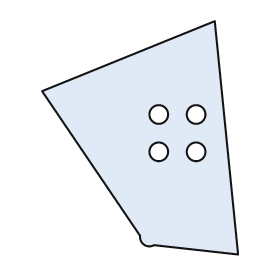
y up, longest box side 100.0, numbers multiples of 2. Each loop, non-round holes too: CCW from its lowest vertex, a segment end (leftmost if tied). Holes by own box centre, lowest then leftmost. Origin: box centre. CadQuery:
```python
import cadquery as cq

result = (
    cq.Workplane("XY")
    .moveTo(42.0, -50.0)
    .lineTo(32.0, 50.0)
    .lineTo(-42.0, 20.0)
    .lineTo(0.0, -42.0)
    .threePointArc((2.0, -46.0), (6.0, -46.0))
    .close()
    .moveTo(8.0, -6.0)
    .circle(4.0)
    .moveTo(24.0, -6.0)
    .circle(4.0)
    .moveTo(8.0, 10.0)
    .circle(4.0)
    .moveTo(24.0, 10.0)
    .circle(4.0)
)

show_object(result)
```